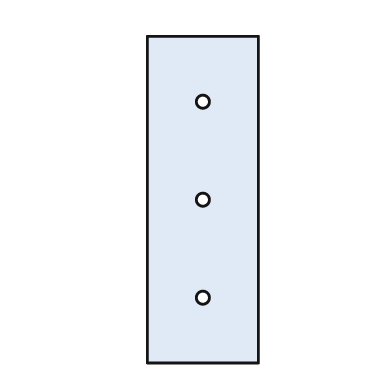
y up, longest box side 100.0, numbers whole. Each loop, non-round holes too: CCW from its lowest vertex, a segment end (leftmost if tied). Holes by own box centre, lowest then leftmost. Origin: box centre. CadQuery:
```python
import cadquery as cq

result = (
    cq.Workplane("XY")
    .moveTo(-17.0, -50.0)
    .lineTo(17.0, -50.0)
    .lineTo(17.0, 50.0)
    .lineTo(-17.0, 50.0)
    .close()
    .moveTo(0.0, -30.0)
    .circle(2.0)
    .moveTo(0.0, 0.0)
    .circle(2.0)
    .moveTo(0.0, 30.0)
    .circle(2.0)
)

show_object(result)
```